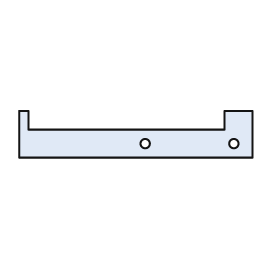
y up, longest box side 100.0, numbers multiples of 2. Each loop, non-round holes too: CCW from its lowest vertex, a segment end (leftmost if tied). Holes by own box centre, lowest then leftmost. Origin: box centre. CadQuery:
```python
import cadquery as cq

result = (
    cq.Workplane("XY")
    .moveTo(-50.0, -10.0)
    .lineTo(50.0, -10.0)
    .lineTo(50.0, 10.0)
    .lineTo(38.0, 10.0)
    .lineTo(38.0, 2.0)
    .lineTo(-46.0, 2.0)
    .lineTo(-46.0, 10.0)
    .lineTo(-50.0, 10.0)
    .close()
    .moveTo(4.0, -4.0)
    .circle(2.0)
    .moveTo(42.0, -4.0)
    .circle(2.0)
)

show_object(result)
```